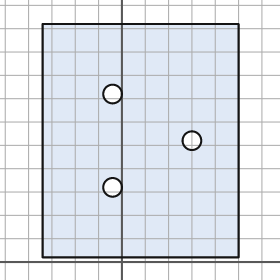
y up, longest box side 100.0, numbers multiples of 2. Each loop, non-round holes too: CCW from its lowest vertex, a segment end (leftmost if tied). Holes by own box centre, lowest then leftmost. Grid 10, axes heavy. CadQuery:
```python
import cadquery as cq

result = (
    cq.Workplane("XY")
    .moveTo(-34.0, 2.0)
    .lineTo(50.0, 2.0)
    .lineTo(50.0, 102.0)
    .lineTo(-34.0, 102.0)
    .close()
    .moveTo(-4.0, 32.0)
    .circle(4.0)
    .moveTo(30.0, 52.0)
    .circle(4.0)
    .moveTo(-4.0, 72.0)
    .circle(4.0)
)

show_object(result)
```